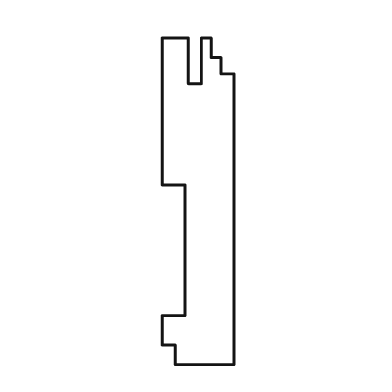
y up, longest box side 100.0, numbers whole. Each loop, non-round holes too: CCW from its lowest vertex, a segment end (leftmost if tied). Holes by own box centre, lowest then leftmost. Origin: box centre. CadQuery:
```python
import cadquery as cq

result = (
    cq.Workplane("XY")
    .moveTo(-7.0, -50.0)
    .lineTo(11.0, -50.0)
    .lineTo(11.0, 39.0)
    .lineTo(7.0, 39.0)
    .lineTo(7.0, 44.0)
    .lineTo(4.0, 44.0)
    .lineTo(4.0, 50.0)
    .lineTo(1.0, 50.0)
    .lineTo(1.0, 36.0)
    .lineTo(-3.0, 36.0)
    .lineTo(-3.0, 50.0)
    .lineTo(-11.0, 50.0)
    .lineTo(-11.0, 5.0)
    .lineTo(-4.0, 5.0)
    .lineTo(-4.0, -35.0)
    .lineTo(-11.0, -35.0)
    .lineTo(-11.0, -44.0)
    .lineTo(-7.0, -44.0)
    .close()
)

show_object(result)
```